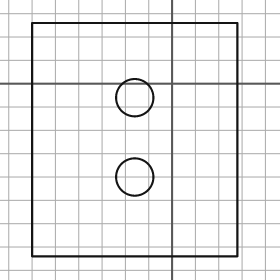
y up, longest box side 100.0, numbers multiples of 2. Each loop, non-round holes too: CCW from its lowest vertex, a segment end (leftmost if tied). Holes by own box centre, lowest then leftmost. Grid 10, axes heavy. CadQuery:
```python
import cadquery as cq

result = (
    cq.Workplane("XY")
    .moveTo(-60.0, -74.0)
    .lineTo(28.0, -74.0)
    .lineTo(28.0, 26.0)
    .lineTo(-60.0, 26.0)
    .close()
    .moveTo(-16.0, -40.0)
    .circle(8.0)
    .moveTo(-16.0, -6.0)
    .circle(8.0)
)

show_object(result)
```